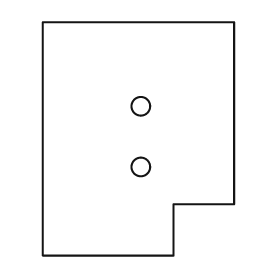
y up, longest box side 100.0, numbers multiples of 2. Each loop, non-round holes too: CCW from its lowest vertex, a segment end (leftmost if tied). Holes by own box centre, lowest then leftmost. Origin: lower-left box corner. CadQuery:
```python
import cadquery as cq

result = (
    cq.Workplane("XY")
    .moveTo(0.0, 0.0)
    .lineTo(56.0, 0.0)
    .lineTo(56.0, 22.0)
    .lineTo(82.0, 22.0)
    .lineTo(82.0, 100.0)
    .lineTo(0.0, 100.0)
    .close()
    .moveTo(42.0, 38.0)
    .circle(4.0)
    .moveTo(42.0, 64.0)
    .circle(4.0)
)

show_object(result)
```